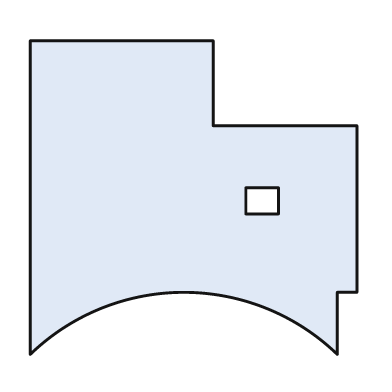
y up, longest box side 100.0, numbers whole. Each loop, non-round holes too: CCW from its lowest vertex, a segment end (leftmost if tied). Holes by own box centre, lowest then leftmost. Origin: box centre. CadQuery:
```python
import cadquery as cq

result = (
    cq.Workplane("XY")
    .moveTo(-50.0, -48.0)
    .threePointArc((-3.0, -29.0), (44.0, -48.0))
    .lineTo(44.0, -29.0)
    .lineTo(50.0, -29.0)
    .lineTo(50.0, 22.0)
    .lineTo(6.0, 22.0)
    .lineTo(6.0, 48.0)
    .lineTo(-50.0, 48.0)
    .close()
    .moveTo(16.0, -5.0)
    .lineTo(26.0, -5.0)
    .lineTo(26.0, 3.0)
    .lineTo(16.0, 3.0)
    .close()
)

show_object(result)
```